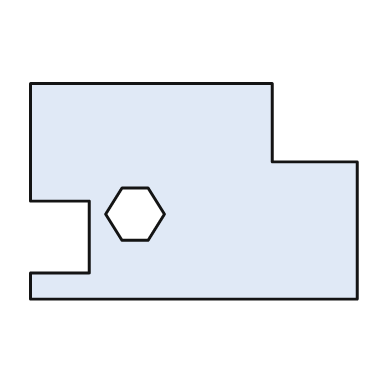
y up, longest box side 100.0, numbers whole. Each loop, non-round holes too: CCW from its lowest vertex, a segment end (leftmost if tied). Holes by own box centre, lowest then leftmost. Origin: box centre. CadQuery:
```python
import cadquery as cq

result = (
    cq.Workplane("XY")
    .moveTo(-50.0, -33.0)
    .lineTo(50.0, -33.0)
    .lineTo(50.0, 9.0)
    .lineTo(24.0, 9.0)
    .lineTo(24.0, 33.0)
    .lineTo(-50.0, 33.0)
    .lineTo(-50.0, -3.0)
    .lineTo(-32.0, -3.0)
    .lineTo(-32.0, -25.0)
    .lineTo(-50.0, -25.0)
    .close()
    .moveTo(-22.0, -15.0)
    .lineTo(-14.0, -15.0)
    .lineTo(-9.0, -7.0)
    .lineTo(-14.0, 1.0)
    .lineTo(-22.0, 1.0)
    .lineTo(-27.0, -7.0)
    .close()
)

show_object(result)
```